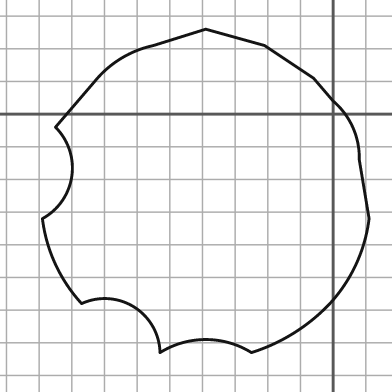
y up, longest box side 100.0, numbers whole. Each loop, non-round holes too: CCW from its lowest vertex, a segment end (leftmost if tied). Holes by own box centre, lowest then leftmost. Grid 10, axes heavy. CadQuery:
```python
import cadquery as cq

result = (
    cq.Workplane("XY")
    .moveTo(-53.0, -73.0)
    .threePointArc((-39.0, -69.0), (-25.0, -73.0))
    .threePointArc((-12.0, -67.0), (-1.0, -58.0))
    .threePointArc((7.0, -46.0), (11.0, -32.0))
    .lineTo(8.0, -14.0)
    .threePointArc((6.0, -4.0), (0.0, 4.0))
    .lineTo(-6.0, 11.0)
    .lineTo(-21.0, 21.0)
    .lineTo(-39.0, 26.0)
    .lineTo(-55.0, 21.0)
    .threePointArc((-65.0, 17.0), (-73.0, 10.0))
    .lineTo(-85.0, -4.0)
    .threePointArc((-80.0, -19.0), (-89.0, -32.0))
    .threePointArc((-85.0, -46.0), (-77.0, -58.0))
    .threePointArc((-61.0, -59.0), (-53.0, -73.0))
    .close()
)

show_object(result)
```